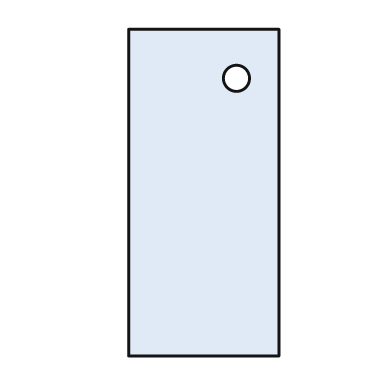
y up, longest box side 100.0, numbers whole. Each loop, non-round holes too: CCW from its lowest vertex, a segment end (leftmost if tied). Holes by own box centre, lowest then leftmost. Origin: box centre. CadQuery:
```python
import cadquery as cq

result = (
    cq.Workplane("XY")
    .moveTo(-23.0, -50.0)
    .lineTo(23.0, -50.0)
    .lineTo(23.0, 50.0)
    .lineTo(-23.0, 50.0)
    .close()
    .moveTo(10.0, 35.0)
    .circle(4.0)
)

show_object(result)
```